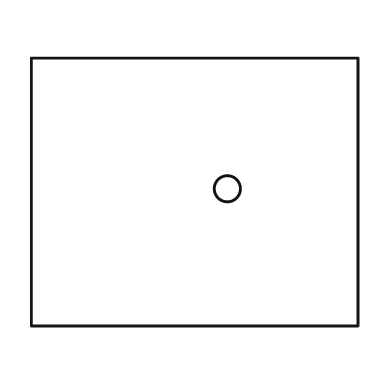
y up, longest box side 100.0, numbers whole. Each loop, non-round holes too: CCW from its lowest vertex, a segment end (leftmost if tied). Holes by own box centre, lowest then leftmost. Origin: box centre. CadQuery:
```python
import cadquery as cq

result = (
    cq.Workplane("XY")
    .moveTo(-50.0, -41.0)
    .lineTo(50.0, -41.0)
    .lineTo(50.0, 41.0)
    .lineTo(-50.0, 41.0)
    .close()
    .moveTo(10.0, 1.0)
    .circle(4.0)
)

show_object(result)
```